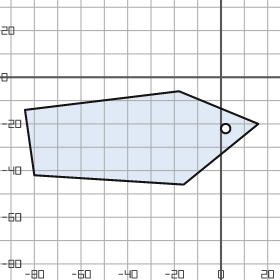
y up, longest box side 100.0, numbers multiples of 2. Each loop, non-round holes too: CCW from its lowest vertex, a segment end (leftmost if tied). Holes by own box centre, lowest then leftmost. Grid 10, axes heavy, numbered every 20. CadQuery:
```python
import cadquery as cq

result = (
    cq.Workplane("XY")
    .moveTo(-16.0, -46.0)
    .lineTo(16.0, -20.0)
    .lineTo(-18.0, -6.0)
    .lineTo(-84.0, -14.0)
    .lineTo(-80.0, -42.0)
    .close()
    .moveTo(2.0, -22.0)
    .circle(2.0)
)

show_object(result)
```